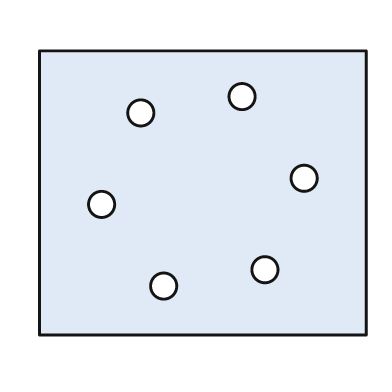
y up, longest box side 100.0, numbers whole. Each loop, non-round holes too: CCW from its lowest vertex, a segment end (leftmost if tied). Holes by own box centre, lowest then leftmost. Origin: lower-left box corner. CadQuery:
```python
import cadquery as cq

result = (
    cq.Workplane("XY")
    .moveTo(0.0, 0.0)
    .lineTo(100.0, 0.0)
    .lineTo(100.0, 87.0)
    .lineTo(0.0, 87.0)
    .close()
    .moveTo(38.0, 15.0)
    .circle(4.0)
    .moveTo(69.0, 20.0)
    .circle(4.0)
    .moveTo(19.0, 40.0)
    .circle(4.0)
    .moveTo(81.0, 48.0)
    .circle(4.0)
    .moveTo(31.0, 68.0)
    .circle(4.0)
    .moveTo(62.0, 73.0)
    .circle(4.0)
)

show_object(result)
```